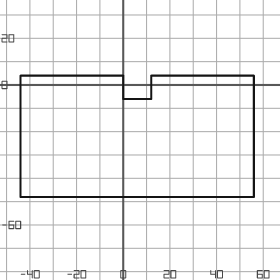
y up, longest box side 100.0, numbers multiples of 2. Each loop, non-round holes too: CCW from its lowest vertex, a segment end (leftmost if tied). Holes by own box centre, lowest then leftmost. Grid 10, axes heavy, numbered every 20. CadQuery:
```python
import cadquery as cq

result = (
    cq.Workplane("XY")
    .moveTo(-44.0, -48.0)
    .lineTo(56.0, -48.0)
    .lineTo(56.0, 4.0)
    .lineTo(12.0, 4.0)
    .lineTo(12.0, -6.0)
    .lineTo(0.0, -6.0)
    .lineTo(0.0, 4.0)
    .lineTo(-44.0, 4.0)
    .close()
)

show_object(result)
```